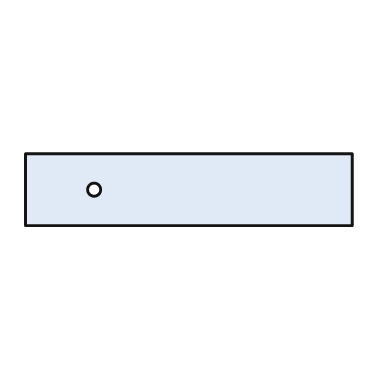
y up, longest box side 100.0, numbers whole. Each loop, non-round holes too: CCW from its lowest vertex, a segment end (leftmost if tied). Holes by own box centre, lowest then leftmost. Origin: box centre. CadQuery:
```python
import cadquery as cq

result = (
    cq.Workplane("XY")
    .moveTo(-50.0, -11.0)
    .lineTo(50.0, -11.0)
    .lineTo(50.0, 11.0)
    .lineTo(-50.0, 11.0)
    .close()
    .moveTo(-29.0, 0.0)
    .circle(2.0)
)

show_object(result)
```